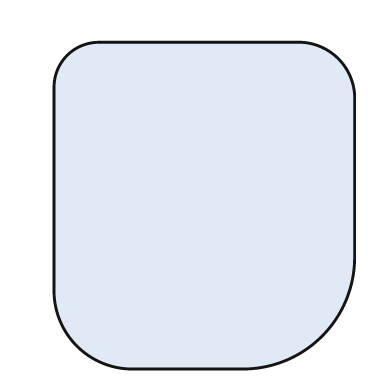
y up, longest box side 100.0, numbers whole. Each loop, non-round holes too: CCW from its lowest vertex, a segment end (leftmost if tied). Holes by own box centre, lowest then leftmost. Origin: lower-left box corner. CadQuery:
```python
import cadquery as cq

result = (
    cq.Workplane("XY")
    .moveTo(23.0, 0.0)
    .lineTo(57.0, 0.0)
    .threePointArc((82.0, 10.0), (92.0, 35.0))
    .lineTo(92.0, 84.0)
    .threePointArc((87.0, 95.0), (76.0, 100.0))
    .lineTo(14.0, 100.0)
    .threePointArc((4.0, 96.0), (0.0, 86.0))
    .lineTo(0.0, 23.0)
    .threePointArc((7.0, 7.0), (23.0, 0.0))
    .close()
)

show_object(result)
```